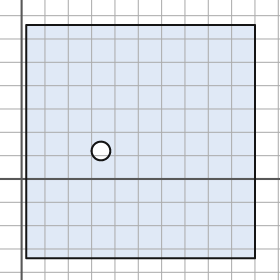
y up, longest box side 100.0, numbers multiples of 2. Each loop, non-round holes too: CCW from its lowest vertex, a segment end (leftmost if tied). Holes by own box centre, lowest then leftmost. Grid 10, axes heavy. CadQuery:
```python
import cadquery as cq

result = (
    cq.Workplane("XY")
    .moveTo(2.0, -34.0)
    .lineTo(100.0, -34.0)
    .lineTo(100.0, 66.0)
    .lineTo(2.0, 66.0)
    .close()
    .moveTo(34.0, 12.0)
    .circle(4.0)
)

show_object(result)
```